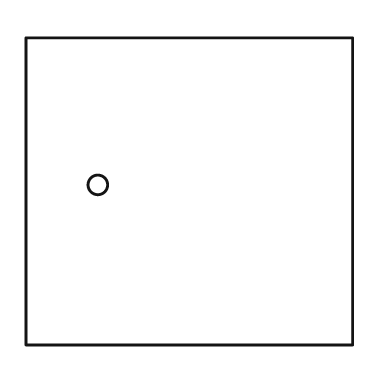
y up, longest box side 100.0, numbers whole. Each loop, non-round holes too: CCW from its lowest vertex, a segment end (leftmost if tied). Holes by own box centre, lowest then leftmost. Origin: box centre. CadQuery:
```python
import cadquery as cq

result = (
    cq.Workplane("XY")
    .moveTo(-50.0, -47.0)
    .lineTo(50.0, -47.0)
    .lineTo(50.0, 47.0)
    .lineTo(-50.0, 47.0)
    .close()
    .moveTo(-28.0, 2.0)
    .circle(3.0)
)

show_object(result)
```